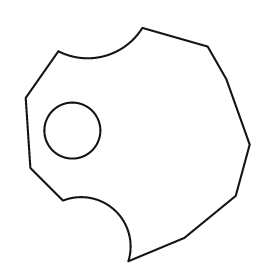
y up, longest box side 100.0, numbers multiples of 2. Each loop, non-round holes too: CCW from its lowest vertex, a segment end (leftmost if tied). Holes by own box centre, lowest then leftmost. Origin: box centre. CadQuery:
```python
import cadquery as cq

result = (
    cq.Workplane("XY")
    .moveTo(-4.0, -50.0)
    .lineTo(20.0, -40.0)
    .lineTo(42.0, -22.0)
    .lineTo(48.0, 0.0)
    .lineTo(38.0, 28.0)
    .lineTo(30.0, 42.0)
    .lineTo(2.0, 50.0)
    .threePointArc((-14.0, 38.0), (-34.0, 40.0))
    .lineTo(-48.0, 20.0)
    .lineTo(-46.0, -10.0)
    .lineTo(-32.0, -24.0)
    .threePointArc((-10.0, -28.0), (-4.0, -50.0))
    .close()
    .moveTo(-28.0, 6.0)
    .circle(12.0)
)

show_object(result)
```